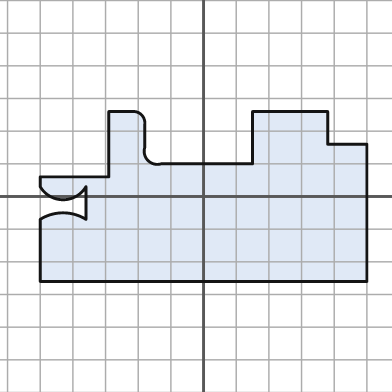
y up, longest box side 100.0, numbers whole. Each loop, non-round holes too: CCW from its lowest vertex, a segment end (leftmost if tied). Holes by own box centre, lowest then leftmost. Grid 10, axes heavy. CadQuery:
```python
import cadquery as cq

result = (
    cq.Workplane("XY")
    .moveTo(-50.0, -26.0)
    .lineTo(50.0, -26.0)
    .lineTo(50.0, 16.0)
    .lineTo(38.0, 16.0)
    .lineTo(38.0, 26.0)
    .lineTo(15.0, 26.0)
    .lineTo(15.0, 10.0)
    .lineTo(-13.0, 10.0)
    .threePointArc((-17.0, 11.0), (-18.0, 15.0))
    .lineTo(-18.0, 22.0)
    .threePointArc((-19.0, 25.0), (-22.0, 26.0))
    .lineTo(-29.0, 26.0)
    .lineTo(-29.0, 6.0)
    .lineTo(-50.0, 6.0)
    .lineTo(-50.0, 3.0)
    .threePointArc((-43.0, -1.0), (-36.0, 3.0))
    .lineTo(-36.0, -7.0)
    .threePointArc((-43.0, -5.0), (-50.0, -7.0))
    .close()
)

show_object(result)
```